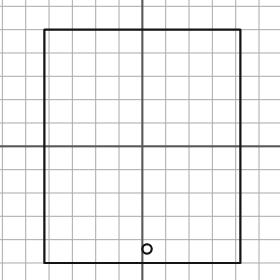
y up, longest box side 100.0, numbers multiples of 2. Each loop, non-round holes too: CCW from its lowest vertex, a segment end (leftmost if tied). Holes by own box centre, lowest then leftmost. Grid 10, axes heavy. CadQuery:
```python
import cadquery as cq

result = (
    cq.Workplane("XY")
    .moveTo(-42.0, -50.0)
    .lineTo(42.0, -50.0)
    .lineTo(42.0, 50.0)
    .lineTo(-42.0, 50.0)
    .close()
    .moveTo(2.0, -44.0)
    .circle(2.0)
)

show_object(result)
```